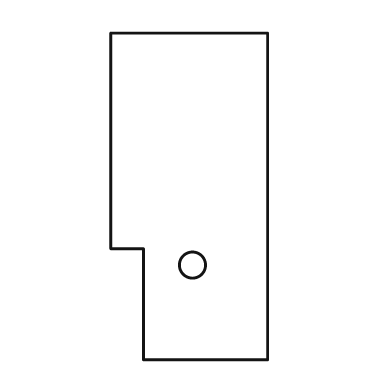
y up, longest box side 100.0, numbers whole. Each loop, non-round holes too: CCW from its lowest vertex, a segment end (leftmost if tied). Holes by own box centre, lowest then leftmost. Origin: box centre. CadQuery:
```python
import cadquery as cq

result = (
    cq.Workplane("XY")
    .moveTo(-14.0, -50.0)
    .lineTo(24.0, -50.0)
    .lineTo(24.0, 50.0)
    .lineTo(-24.0, 50.0)
    .lineTo(-24.0, -16.0)
    .lineTo(-14.0, -16.0)
    .close()
    .moveTo(1.0, -21.0)
    .circle(4.0)
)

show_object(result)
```